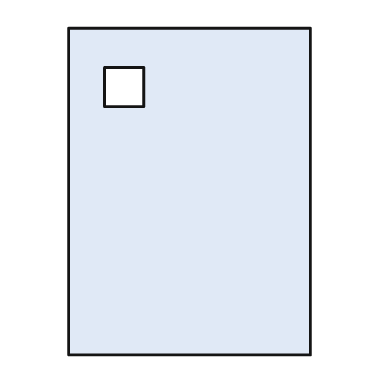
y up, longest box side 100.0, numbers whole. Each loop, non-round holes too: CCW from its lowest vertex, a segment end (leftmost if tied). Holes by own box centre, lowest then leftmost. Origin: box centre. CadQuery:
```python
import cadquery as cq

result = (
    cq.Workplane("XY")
    .moveTo(-37.0, -50.0)
    .lineTo(37.0, -50.0)
    .lineTo(37.0, 50.0)
    .lineTo(-37.0, 50.0)
    .close()
    .moveTo(-26.0, 26.0)
    .lineTo(-14.0, 26.0)
    .lineTo(-14.0, 38.0)
    .lineTo(-26.0, 38.0)
    .close()
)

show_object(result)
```